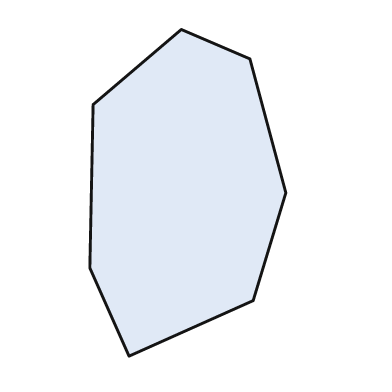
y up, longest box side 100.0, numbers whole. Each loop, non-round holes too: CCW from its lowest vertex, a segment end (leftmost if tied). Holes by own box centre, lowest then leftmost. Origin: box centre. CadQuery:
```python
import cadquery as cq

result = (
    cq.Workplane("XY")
    .moveTo(-18.0, -50.0)
    .lineTo(20.0, -33.0)
    .lineTo(30.0, 0.0)
    .lineTo(19.0, 41.0)
    .lineTo(-2.0, 50.0)
    .lineTo(-29.0, 27.0)
    .lineTo(-30.0, -23.0)
    .close()
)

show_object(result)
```